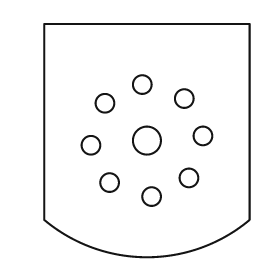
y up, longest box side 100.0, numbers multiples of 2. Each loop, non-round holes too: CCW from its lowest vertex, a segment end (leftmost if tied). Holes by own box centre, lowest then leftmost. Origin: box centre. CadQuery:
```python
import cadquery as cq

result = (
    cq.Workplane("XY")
    .moveTo(-44.0, -34.0)
    .threePointArc((0.0, -50.0), (44.0, -34.0))
    .lineTo(44.0, 50.0)
    .lineTo(-44.0, 50.0)
    .close()
    .moveTo(2.0, -24.0)
    .circle(4.0)
    .moveTo(-16.0, -18.0)
    .circle(4.0)
    .moveTo(18.0, -16.0)
    .circle(4.0)
    .moveTo(-24.0, -2.0)
    .circle(4.0)
    .moveTo(0.0, 0.0)
    .circle(6.0)
    .moveTo(24.0, 2.0)
    .circle(4.0)
    .moveTo(-18.0, 16.0)
    .circle(4.0)
    .moveTo(16.0, 18.0)
    .circle(4.0)
    .moveTo(-2.0, 24.0)
    .circle(4.0)
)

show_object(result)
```